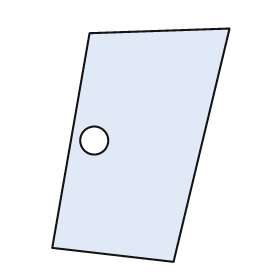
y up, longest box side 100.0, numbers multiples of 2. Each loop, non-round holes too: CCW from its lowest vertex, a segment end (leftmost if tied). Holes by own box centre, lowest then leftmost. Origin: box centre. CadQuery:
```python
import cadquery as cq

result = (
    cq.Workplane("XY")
    .moveTo(14.0, -50.0)
    .lineTo(38.0, 50.0)
    .lineTo(-22.0, 48.0)
    .lineTo(-38.0, -44.0)
    .close()
    .moveTo(-20.0, 2.0)
    .circle(6.0)
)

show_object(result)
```